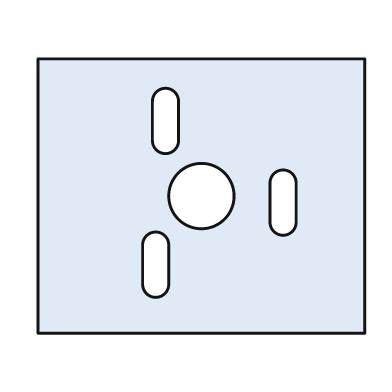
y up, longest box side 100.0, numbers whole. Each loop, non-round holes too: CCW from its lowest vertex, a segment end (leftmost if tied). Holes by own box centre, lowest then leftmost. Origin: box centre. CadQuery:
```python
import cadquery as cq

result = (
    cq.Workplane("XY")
    .moveTo(-50.0, -42.0)
    .lineTo(50.0, -42.0)
    .lineTo(50.0, 42.0)
    .lineTo(-50.0, 42.0)
    .close()
    .moveTo(-18.0, -27.0)
    .threePointArc((-14.0, -31.0), (-10.0, -27.0))
    .lineTo(-10.0, -15.0)
    .threePointArc((-14.0, -11.0), (-18.0, -15.0))
    .close()
    .moveTo(21.0, -8.0)
    .threePointArc((25.0, -12.0), (29.0, -8.0))
    .lineTo(29.0, 4.0)
    .threePointArc((25.0, 8.0), (21.0, 4.0))
    .close()
    .moveTo(0.0, 0.0)
    .circle(10.0)
    .moveTo(-15.0, 17.0)
    .threePointArc((-11.0, 13.0), (-7.0, 17.0))
    .lineTo(-7.0, 29.0)
    .threePointArc((-11.0, 33.0), (-15.0, 29.0))
    .close()
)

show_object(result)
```